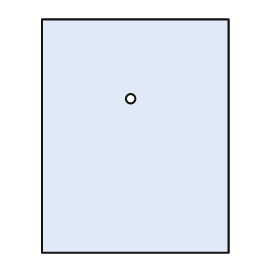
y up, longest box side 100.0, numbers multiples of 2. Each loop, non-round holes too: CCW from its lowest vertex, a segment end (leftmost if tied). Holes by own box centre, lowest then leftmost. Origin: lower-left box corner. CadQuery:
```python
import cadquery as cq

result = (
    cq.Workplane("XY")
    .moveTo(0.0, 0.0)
    .lineTo(80.0, 0.0)
    .lineTo(80.0, 100.0)
    .lineTo(0.0, 100.0)
    .close()
    .moveTo(38.0, 66.0)
    .circle(2.0)
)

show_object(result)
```